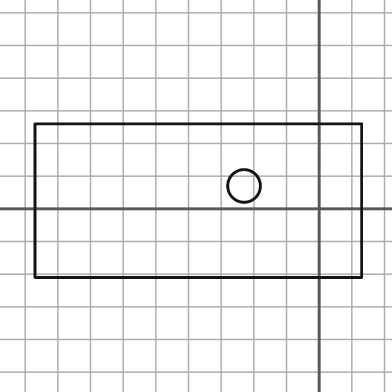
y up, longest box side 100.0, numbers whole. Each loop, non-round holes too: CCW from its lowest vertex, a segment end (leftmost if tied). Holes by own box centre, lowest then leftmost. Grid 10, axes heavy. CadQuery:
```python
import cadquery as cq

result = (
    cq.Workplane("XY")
    .moveTo(-87.0, -21.0)
    .lineTo(13.0, -21.0)
    .lineTo(13.0, 26.0)
    .lineTo(-87.0, 26.0)
    .close()
    .moveTo(-23.0, 7.0)
    .circle(5.0)
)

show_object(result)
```